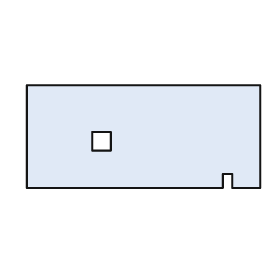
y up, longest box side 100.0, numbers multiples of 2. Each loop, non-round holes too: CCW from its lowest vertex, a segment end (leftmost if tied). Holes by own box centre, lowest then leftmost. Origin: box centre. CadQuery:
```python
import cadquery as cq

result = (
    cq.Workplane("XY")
    .moveTo(-50.0, -22.0)
    .lineTo(34.0, -22.0)
    .lineTo(34.0, -16.0)
    .lineTo(38.0, -16.0)
    .lineTo(38.0, -22.0)
    .lineTo(50.0, -22.0)
    .lineTo(50.0, 22.0)
    .lineTo(-50.0, 22.0)
    .close()
    .moveTo(-22.0, -6.0)
    .lineTo(-14.0, -6.0)
    .lineTo(-14.0, 2.0)
    .lineTo(-22.0, 2.0)
    .close()
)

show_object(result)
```